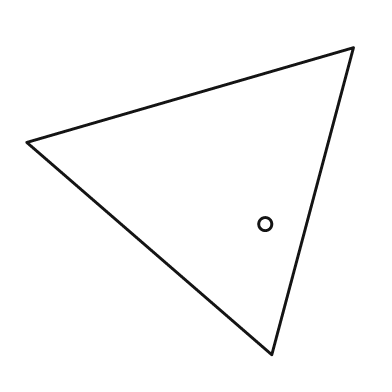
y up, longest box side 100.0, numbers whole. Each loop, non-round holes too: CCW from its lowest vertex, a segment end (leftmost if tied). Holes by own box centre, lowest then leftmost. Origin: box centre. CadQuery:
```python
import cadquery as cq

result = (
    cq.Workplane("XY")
    .moveTo(25.0, -47.0)
    .lineTo(50.0, 47.0)
    .lineTo(-50.0, 18.0)
    .close()
    .moveTo(23.0, -7.0)
    .circle(2.0)
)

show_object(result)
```